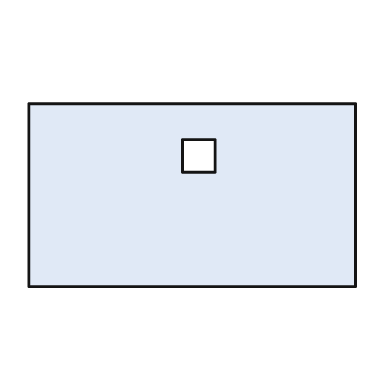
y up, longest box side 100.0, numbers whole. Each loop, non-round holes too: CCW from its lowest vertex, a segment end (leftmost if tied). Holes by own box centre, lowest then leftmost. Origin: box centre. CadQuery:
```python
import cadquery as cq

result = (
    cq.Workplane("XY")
    .moveTo(-50.0, -28.0)
    .lineTo(50.0, -28.0)
    .lineTo(50.0, 28.0)
    .lineTo(-50.0, 28.0)
    .close()
    .moveTo(-3.0, 7.0)
    .lineTo(7.0, 7.0)
    .lineTo(7.0, 17.0)
    .lineTo(-3.0, 17.0)
    .close()
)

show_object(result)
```